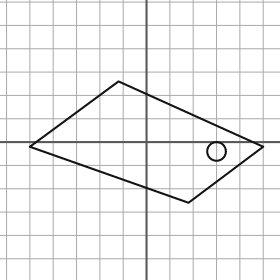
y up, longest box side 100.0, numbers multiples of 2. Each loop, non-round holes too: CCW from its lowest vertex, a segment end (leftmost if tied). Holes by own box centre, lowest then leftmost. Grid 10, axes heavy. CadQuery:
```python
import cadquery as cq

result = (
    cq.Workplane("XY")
    .moveTo(18.0, -26.0)
    .lineTo(50.0, -2.0)
    .lineTo(-12.0, 26.0)
    .lineTo(-50.0, -2.0)
    .close()
    .moveTo(30.0, -4.0)
    .circle(4.0)
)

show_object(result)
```